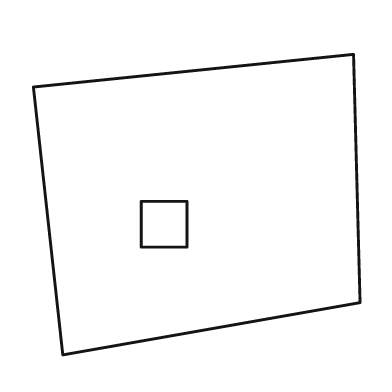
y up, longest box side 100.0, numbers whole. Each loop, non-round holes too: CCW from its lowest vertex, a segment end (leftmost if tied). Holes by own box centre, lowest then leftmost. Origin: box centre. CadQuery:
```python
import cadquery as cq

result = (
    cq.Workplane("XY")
    .moveTo(-41.0, -46.0)
    .lineTo(50.0, -30.0)
    .lineTo(48.0, 46.0)
    .lineTo(-50.0, 36.0)
    .close()
    .moveTo(-17.0, -13.0)
    .lineTo(-3.0, -13.0)
    .lineTo(-3.0, 1.0)
    .lineTo(-17.0, 1.0)
    .close()
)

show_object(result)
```